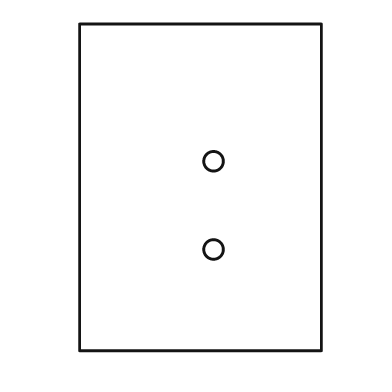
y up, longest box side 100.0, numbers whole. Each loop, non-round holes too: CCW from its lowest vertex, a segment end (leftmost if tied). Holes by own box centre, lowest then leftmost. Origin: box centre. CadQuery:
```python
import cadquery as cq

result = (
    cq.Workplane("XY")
    .moveTo(-37.0, -50.0)
    .lineTo(37.0, -50.0)
    .lineTo(37.0, 50.0)
    .lineTo(-37.0, 50.0)
    .close()
    .moveTo(4.0, -19.0)
    .circle(3.0)
    .moveTo(4.0, 8.0)
    .circle(3.0)
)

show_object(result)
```